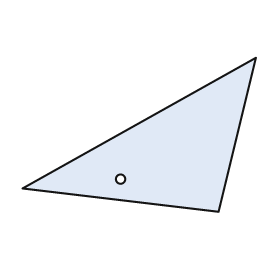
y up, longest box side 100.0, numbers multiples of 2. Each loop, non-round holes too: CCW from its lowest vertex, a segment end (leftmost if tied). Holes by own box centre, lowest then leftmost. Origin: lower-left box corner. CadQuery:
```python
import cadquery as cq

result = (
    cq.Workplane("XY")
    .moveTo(84.0, 0.0)
    .lineTo(100.0, 66.0)
    .lineTo(0.0, 10.0)
    .close()
    .moveTo(42.0, 14.0)
    .circle(2.0)
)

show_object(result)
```